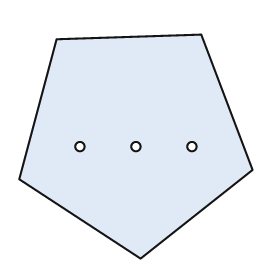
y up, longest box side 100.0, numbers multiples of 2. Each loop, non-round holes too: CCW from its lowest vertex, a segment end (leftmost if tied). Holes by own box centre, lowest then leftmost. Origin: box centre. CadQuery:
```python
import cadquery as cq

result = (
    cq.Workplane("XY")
    .moveTo(2.0, -48.0)
    .lineTo(50.0, -10.0)
    .lineTo(28.0, 48.0)
    .lineTo(-34.0, 46.0)
    .lineTo(-50.0, -14.0)
    .close()
    .moveTo(-24.0, 0.0)
    .circle(2.0)
    .moveTo(0.0, 0.0)
    .circle(2.0)
    .moveTo(24.0, 0.0)
    .circle(2.0)
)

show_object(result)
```